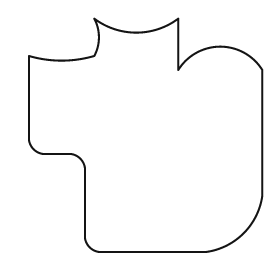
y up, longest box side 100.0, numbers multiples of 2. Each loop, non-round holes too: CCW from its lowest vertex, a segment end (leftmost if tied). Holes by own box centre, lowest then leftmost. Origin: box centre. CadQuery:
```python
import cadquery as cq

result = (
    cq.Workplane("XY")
    .moveTo(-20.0, -50.0)
    .lineTo(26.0, -50.0)
    .threePointArc((42.0, -42.0), (50.0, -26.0))
    .lineTo(50.0, 28.0)
    .threePointArc((32.0, 38.0), (14.0, 28.0))
    .lineTo(14.0, 50.0)
    .threePointArc((-4.0, 44.0), (-22.0, 50.0))
    .threePointArc((-20.0, 42.0), (-22.0, 34.0))
    .threePointArc((-36.0, 32.0), (-50.0, 34.0))
    .lineTo(-50.0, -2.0)
    .threePointArc((-48.0, -6.0), (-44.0, -8.0))
    .lineTo(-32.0, -8.0)
    .threePointArc((-28.0, -10.0), (-26.0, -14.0))
    .lineTo(-26.0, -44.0)
    .threePointArc((-24.0, -48.0), (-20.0, -50.0))
    .close()
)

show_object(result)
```